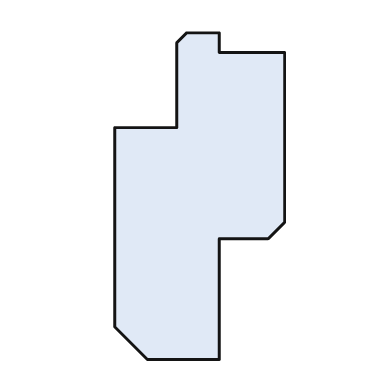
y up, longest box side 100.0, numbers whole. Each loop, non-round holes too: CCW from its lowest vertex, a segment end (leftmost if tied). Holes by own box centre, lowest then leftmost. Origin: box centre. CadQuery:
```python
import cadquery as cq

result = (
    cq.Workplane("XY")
    .moveTo(-16.0, -50.0)
    .lineTo(6.0, -50.0)
    .lineTo(6.0, -13.0)
    .lineTo(21.0, -13.0)
    .lineTo(26.0, -8.0)
    .lineTo(26.0, 44.0)
    .lineTo(6.0, 44.0)
    .lineTo(6.0, 50.0)
    .lineTo(-4.0, 50.0)
    .lineTo(-7.0, 47.0)
    .lineTo(-7.0, 21.0)
    .lineTo(-26.0, 21.0)
    .lineTo(-26.0, -40.0)
    .close()
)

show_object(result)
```